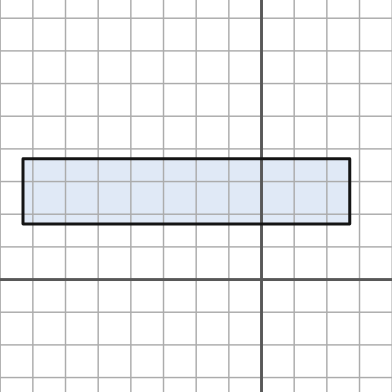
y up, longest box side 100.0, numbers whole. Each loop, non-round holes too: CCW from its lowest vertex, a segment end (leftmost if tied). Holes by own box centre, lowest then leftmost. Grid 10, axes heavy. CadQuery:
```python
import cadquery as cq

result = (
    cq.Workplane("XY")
    .moveTo(-73.0, 17.0)
    .lineTo(27.0, 17.0)
    .lineTo(27.0, 37.0)
    .lineTo(-73.0, 37.0)
    .close()
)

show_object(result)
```